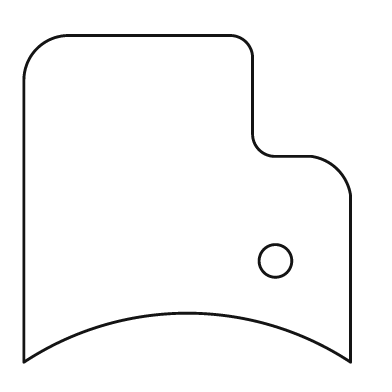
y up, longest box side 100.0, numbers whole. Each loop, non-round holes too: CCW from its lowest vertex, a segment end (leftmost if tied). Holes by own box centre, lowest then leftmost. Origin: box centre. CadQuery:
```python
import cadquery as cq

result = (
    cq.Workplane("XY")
    .moveTo(-50.0, -50.0)
    .threePointArc((0.0, -35.0), (50.0, -50.0))
    .lineTo(50.0, 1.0)
    .threePointArc((46.0, 9.0), (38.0, 13.0))
    .lineTo(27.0, 13.0)
    .threePointArc((22.0, 15.0), (20.0, 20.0))
    .lineTo(20.0, 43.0)
    .threePointArc((18.0, 48.0), (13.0, 50.0))
    .lineTo(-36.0, 50.0)
    .threePointArc((-46.0, 46.0), (-50.0, 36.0))
    .close()
    .moveTo(27.0, -19.0)
    .circle(5.0)
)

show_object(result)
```